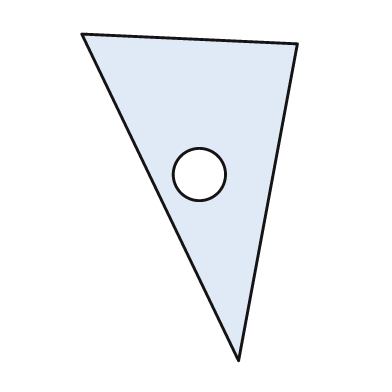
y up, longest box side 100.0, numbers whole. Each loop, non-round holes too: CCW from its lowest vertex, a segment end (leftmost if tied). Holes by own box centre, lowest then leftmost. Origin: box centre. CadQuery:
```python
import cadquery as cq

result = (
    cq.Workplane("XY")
    .moveTo(15.0, -50.0)
    .lineTo(33.0, 47.0)
    .lineTo(-33.0, 50.0)
    .close()
    .moveTo(3.0, 7.0)
    .circle(8.0)
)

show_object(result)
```